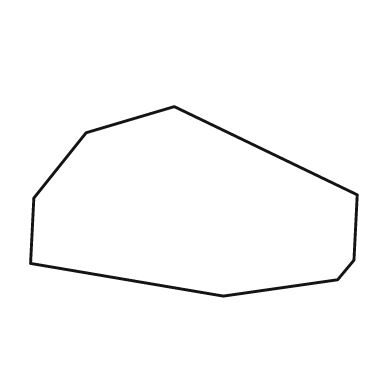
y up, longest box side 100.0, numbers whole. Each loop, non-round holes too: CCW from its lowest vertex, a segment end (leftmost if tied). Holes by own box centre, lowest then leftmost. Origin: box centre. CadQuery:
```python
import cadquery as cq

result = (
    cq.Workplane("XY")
    .moveTo(9.0, -29.0)
    .lineTo(44.0, -24.0)
    .lineTo(49.0, -18.0)
    .lineTo(50.0, 2.0)
    .lineTo(-6.0, 29.0)
    .lineTo(-33.0, 21.0)
    .lineTo(-49.0, 1.0)
    .lineTo(-50.0, -19.0)
    .close()
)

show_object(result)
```